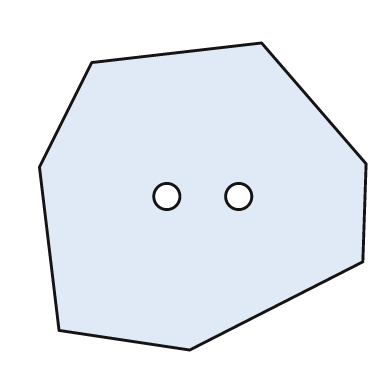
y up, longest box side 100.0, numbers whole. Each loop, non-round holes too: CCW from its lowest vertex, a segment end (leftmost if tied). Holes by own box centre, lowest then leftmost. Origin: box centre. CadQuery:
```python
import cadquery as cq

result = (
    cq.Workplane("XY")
    .moveTo(-4.0, -47.0)
    .lineTo(49.0, -20.0)
    .lineTo(50.0, 10.0)
    .lineTo(18.0, 47.0)
    .lineTo(-34.0, 41.0)
    .lineTo(-50.0, 9.0)
    .lineTo(-44.0, -41.0)
    .close()
    .moveTo(-11.0, 0.0)
    .circle(4.0)
    .moveTo(11.0, 0.0)
    .circle(4.0)
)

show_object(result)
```